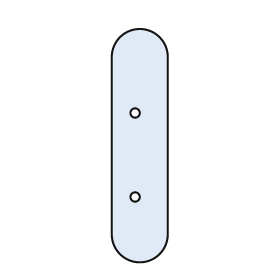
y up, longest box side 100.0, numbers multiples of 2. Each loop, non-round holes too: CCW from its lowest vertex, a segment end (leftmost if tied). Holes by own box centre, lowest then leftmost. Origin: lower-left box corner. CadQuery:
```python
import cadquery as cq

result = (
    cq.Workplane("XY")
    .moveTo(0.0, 12.0)
    .threePointArc((12.0, 0.0), (24.0, 12.0))
    .lineTo(24.0, 88.0)
    .threePointArc((12.0, 100.0), (0.0, 88.0))
    .close()
    .moveTo(10.0, 28.0)
    .circle(2.0)
    .moveTo(10.0, 64.0)
    .circle(2.0)
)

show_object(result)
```